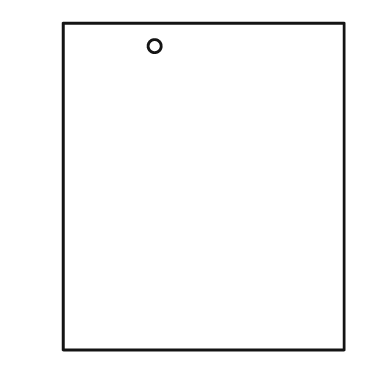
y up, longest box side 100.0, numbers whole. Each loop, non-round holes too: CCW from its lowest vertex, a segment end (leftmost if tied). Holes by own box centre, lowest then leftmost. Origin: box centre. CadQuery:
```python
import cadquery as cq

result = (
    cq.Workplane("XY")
    .moveTo(-43.0, -50.0)
    .lineTo(43.0, -50.0)
    .lineTo(43.0, 50.0)
    .lineTo(-43.0, 50.0)
    .close()
    .moveTo(-15.0, 43.0)
    .circle(2.0)
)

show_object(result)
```